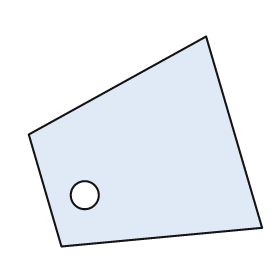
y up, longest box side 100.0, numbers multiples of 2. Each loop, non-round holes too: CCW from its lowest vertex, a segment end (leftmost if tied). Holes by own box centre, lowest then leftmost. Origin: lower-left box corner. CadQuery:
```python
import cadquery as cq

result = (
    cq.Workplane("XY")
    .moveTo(14.0, 0.0)
    .lineTo(100.0, 8.0)
    .lineTo(76.0, 90.0)
    .lineTo(0.0, 48.0)
    .close()
    .moveTo(24.0, 22.0)
    .circle(6.0)
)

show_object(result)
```